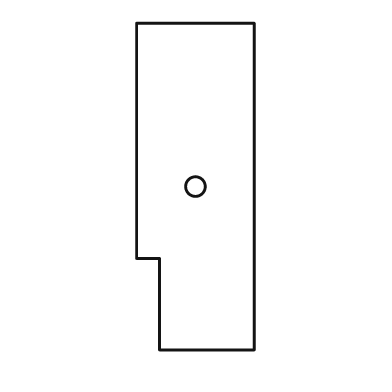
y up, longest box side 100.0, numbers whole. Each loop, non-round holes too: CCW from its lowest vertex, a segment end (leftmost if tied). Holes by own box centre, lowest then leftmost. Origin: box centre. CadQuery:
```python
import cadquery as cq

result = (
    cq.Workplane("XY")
    .moveTo(-11.0, -50.0)
    .lineTo(18.0, -50.0)
    .lineTo(18.0, 50.0)
    .lineTo(-18.0, 50.0)
    .lineTo(-18.0, -22.0)
    .lineTo(-11.0, -22.0)
    .close()
    .moveTo(0.0, 0.0)
    .circle(3.0)
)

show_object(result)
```